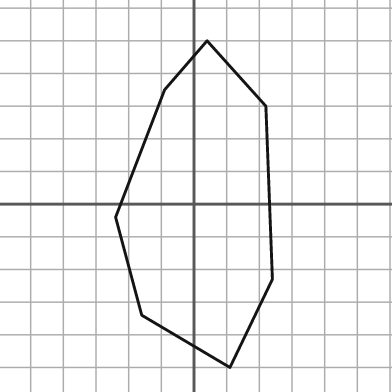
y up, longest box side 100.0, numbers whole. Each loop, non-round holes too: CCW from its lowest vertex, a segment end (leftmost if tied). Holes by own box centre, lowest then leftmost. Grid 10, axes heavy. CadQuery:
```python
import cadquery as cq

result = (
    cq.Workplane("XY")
    .moveTo(11.0, -50.0)
    .lineTo(24.0, -23.0)
    .lineTo(22.0, 30.0)
    .lineTo(4.0, 50.0)
    .lineTo(-9.0, 35.0)
    .lineTo(-24.0, -4.0)
    .lineTo(-16.0, -34.0)
    .close()
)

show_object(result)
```